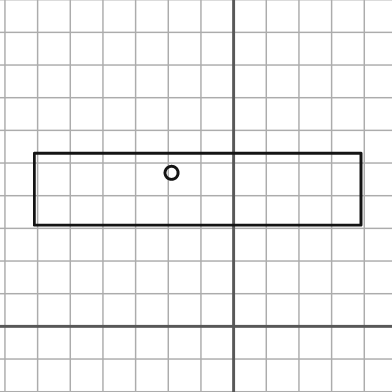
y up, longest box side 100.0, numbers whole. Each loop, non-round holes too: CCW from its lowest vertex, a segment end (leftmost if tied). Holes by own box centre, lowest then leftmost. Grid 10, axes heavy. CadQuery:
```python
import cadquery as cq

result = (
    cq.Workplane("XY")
    .moveTo(-61.0, 31.0)
    .lineTo(39.0, 31.0)
    .lineTo(39.0, 53.0)
    .lineTo(-61.0, 53.0)
    .close()
    .moveTo(-19.0, 47.0)
    .circle(2.0)
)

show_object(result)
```